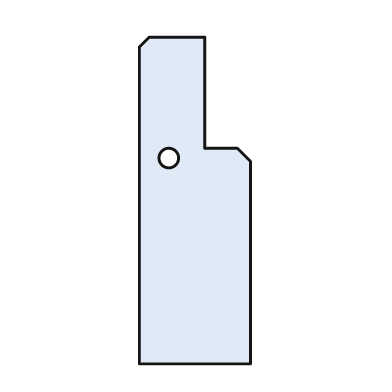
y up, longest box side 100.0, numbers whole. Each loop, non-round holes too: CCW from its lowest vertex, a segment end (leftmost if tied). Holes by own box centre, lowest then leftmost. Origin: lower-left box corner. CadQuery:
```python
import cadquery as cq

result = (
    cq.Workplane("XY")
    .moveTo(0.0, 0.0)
    .lineTo(34.0, 0.0)
    .lineTo(34.0, 62.0)
    .lineTo(30.0, 66.0)
    .lineTo(20.0, 66.0)
    .lineTo(20.0, 100.0)
    .lineTo(3.0, 100.0)
    .lineTo(0.0, 97.0)
    .close()
    .moveTo(9.0, 63.0)
    .circle(3.0)
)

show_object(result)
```